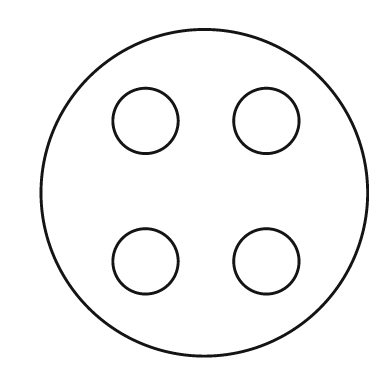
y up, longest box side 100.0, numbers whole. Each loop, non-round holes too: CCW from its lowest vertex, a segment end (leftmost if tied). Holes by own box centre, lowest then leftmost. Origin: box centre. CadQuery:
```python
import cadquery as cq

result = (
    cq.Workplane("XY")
    .moveTo(0.0, 0.0)
    .circle(50.0)
    .moveTo(-18.0, -21.0)
    .circle(10.0)
    .moveTo(19.0, -21.0)
    .circle(10.0)
    .moveTo(-18.0, 22.0)
    .circle(10.0)
    .moveTo(19.0, 22.0)
    .circle(10.0)
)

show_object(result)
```